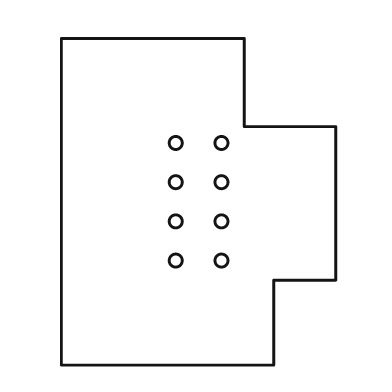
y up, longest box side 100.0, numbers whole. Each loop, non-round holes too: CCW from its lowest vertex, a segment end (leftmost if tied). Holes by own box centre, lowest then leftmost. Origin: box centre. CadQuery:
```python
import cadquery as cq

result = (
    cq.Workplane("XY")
    .moveTo(-42.0, -50.0)
    .lineTo(23.0, -50.0)
    .lineTo(23.0, -24.0)
    .lineTo(42.0, -24.0)
    .lineTo(42.0, 23.0)
    .lineTo(14.0, 23.0)
    .lineTo(14.0, 50.0)
    .lineTo(-42.0, 50.0)
    .close()
    .moveTo(-7.0, -18.0)
    .circle(2.0)
    .moveTo(7.0, -18.0)
    .circle(2.0)
    .moveTo(-7.0, -6.0)
    .circle(2.0)
    .moveTo(7.0, -6.0)
    .circle(2.0)
    .moveTo(-7.0, 6.0)
    .circle(2.0)
    .moveTo(7.0, 6.0)
    .circle(2.0)
    .moveTo(-7.0, 18.0)
    .circle(2.0)
    .moveTo(7.0, 18.0)
    .circle(2.0)
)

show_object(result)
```